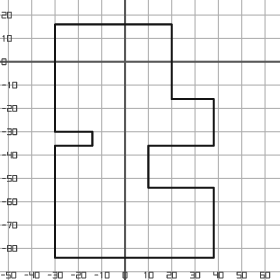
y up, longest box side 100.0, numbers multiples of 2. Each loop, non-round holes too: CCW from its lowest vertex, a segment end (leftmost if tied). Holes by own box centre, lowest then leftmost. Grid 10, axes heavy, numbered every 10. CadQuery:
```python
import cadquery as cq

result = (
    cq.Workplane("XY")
    .moveTo(-30.0, -84.0)
    .lineTo(38.0, -84.0)
    .lineTo(38.0, -54.0)
    .lineTo(10.0, -54.0)
    .lineTo(10.0, -36.0)
    .lineTo(38.0, -36.0)
    .lineTo(38.0, -16.0)
    .lineTo(20.0, -16.0)
    .lineTo(20.0, 16.0)
    .lineTo(-30.0, 16.0)
    .lineTo(-30.0, -30.0)
    .lineTo(-14.0, -30.0)
    .lineTo(-14.0, -36.0)
    .lineTo(-30.0, -36.0)
    .close()
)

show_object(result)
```